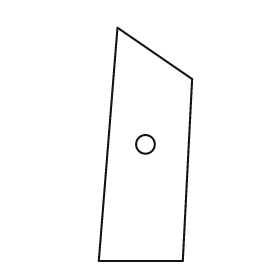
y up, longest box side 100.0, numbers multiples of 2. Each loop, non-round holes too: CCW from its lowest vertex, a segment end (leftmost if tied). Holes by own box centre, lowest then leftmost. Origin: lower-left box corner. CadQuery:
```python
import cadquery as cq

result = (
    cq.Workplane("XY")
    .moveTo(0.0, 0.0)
    .lineTo(36.0, 0.0)
    .lineTo(40.0, 78.0)
    .lineTo(8.0, 100.0)
    .close()
    .moveTo(20.0, 50.0)
    .circle(4.0)
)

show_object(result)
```